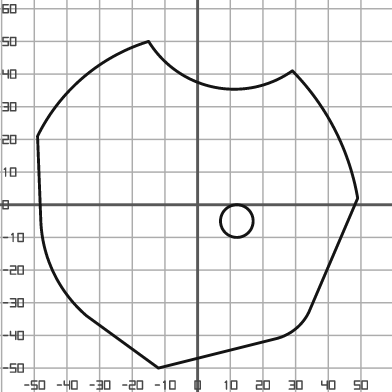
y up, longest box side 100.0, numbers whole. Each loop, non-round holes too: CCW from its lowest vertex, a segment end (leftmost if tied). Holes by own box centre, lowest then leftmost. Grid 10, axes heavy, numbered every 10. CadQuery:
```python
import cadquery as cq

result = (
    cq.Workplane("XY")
    .moveTo(-12.0, -50.0)
    .lineTo(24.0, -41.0)
    .threePointArc((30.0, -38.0), (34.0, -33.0))
    .lineTo(49.0, 2.0)
    .threePointArc((42.0, 23.0), (29.0, 41.0))
    .threePointArc((5.0, 36.0), (-15.0, 50.0))
    .threePointArc((-35.0, 39.0), (-49.0, 21.0))
    .lineTo(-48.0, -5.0)
    .threePointArc((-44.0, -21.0), (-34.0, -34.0))
    .close()
    .moveTo(12.0, -5.0)
    .circle(5.0)
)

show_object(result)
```